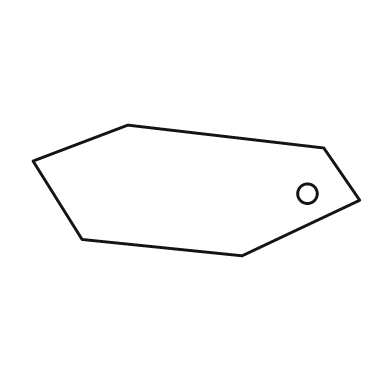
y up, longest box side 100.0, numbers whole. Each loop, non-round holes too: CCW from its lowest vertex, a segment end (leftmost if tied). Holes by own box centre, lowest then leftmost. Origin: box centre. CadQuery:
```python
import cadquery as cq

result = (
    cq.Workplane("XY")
    .moveTo(14.0, -20.0)
    .lineTo(50.0, -3.0)
    .lineTo(39.0, 13.0)
    .lineTo(-21.0, 20.0)
    .lineTo(-50.0, 9.0)
    .lineTo(-35.0, -15.0)
    .close()
    .moveTo(34.0, -1.0)
    .circle(3.0)
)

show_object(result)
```